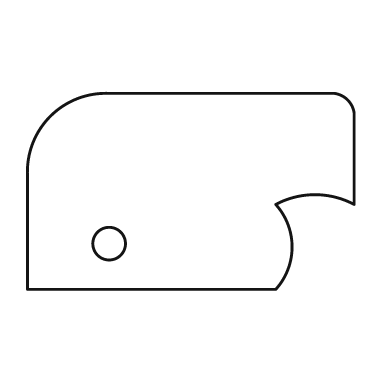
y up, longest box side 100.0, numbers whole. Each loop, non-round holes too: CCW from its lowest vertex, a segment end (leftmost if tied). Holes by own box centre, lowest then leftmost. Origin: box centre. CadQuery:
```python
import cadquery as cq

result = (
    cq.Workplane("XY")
    .moveTo(-50.0, -30.0)
    .lineTo(26.0, -30.0)
    .threePointArc((31.0, -17.0), (26.0, -4.0))
    .threePointArc((38.0, -1.0), (50.0, -4.0))
    .lineTo(50.0, 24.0)
    .threePointArc((48.0, 28.0), (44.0, 30.0))
    .lineTo(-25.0, 30.0)
    .threePointArc((-43.0, 23.0), (-50.0, 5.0))
    .close()
    .moveTo(-25.0, -16.0)
    .circle(5.0)
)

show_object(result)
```